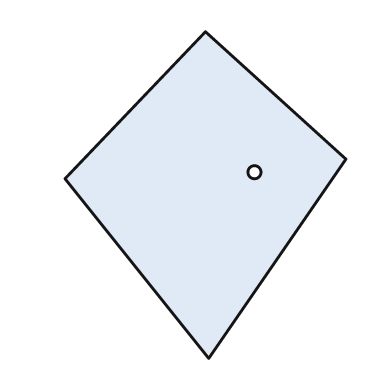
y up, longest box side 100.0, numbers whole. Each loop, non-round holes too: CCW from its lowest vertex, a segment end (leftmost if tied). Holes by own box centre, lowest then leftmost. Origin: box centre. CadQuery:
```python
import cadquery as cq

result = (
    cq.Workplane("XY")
    .moveTo(1.0, -50.0)
    .lineTo(43.0, 11.0)
    .lineTo(0.0, 50.0)
    .lineTo(-43.0, 5.0)
    .close()
    .moveTo(15.0, 7.0)
    .circle(2.0)
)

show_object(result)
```